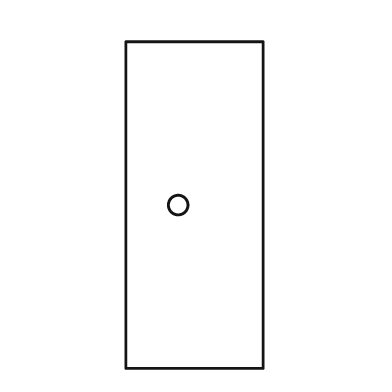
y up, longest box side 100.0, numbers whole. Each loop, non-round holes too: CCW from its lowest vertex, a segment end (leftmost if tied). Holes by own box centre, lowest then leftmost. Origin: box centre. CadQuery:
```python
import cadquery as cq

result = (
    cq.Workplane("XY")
    .moveTo(-21.0, -50.0)
    .lineTo(21.0, -50.0)
    .lineTo(21.0, 50.0)
    .lineTo(-21.0, 50.0)
    .close()
    .moveTo(-5.0, 0.0)
    .circle(3.0)
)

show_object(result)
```